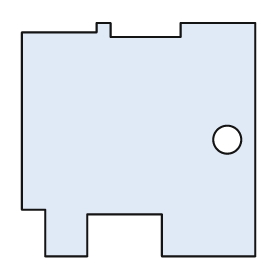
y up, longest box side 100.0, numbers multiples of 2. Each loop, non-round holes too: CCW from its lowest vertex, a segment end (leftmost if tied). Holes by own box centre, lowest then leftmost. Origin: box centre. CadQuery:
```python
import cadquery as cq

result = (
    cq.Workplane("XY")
    .moveTo(-40.0, -50.0)
    .lineTo(-22.0, -50.0)
    .lineTo(-22.0, -32.0)
    .lineTo(10.0, -32.0)
    .lineTo(10.0, -50.0)
    .lineTo(50.0, -50.0)
    .lineTo(50.0, 50.0)
    .lineTo(18.0, 50.0)
    .lineTo(18.0, 44.0)
    .lineTo(-12.0, 44.0)
    .lineTo(-12.0, 50.0)
    .lineTo(-18.0, 50.0)
    .lineTo(-18.0, 46.0)
    .lineTo(-50.0, 46.0)
    .lineTo(-50.0, -30.0)
    .lineTo(-40.0, -30.0)
    .close()
    .moveTo(38.0, 0.0)
    .circle(6.0)
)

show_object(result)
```